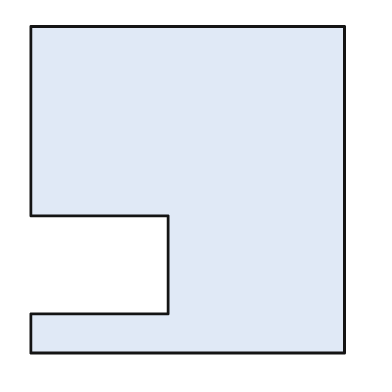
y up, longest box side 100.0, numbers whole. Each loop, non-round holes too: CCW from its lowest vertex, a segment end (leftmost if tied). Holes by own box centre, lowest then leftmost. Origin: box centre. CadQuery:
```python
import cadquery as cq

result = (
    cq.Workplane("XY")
    .moveTo(-48.0, -50.0)
    .lineTo(48.0, -50.0)
    .lineTo(48.0, 50.0)
    .lineTo(-48.0, 50.0)
    .lineTo(-48.0, -8.0)
    .lineTo(-6.0, -8.0)
    .lineTo(-6.0, -38.0)
    .lineTo(-48.0, -38.0)
    .close()
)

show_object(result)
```